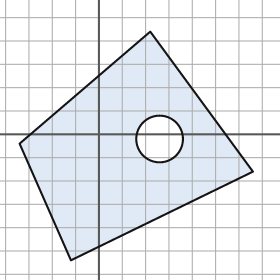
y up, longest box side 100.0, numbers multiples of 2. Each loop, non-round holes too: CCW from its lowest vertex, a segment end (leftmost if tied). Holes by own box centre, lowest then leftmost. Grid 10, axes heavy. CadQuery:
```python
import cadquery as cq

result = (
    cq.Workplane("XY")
    .moveTo(-12.0, -54.0)
    .lineTo(66.0, -16.0)
    .lineTo(22.0, 44.0)
    .lineTo(-34.0, -4.0)
    .close()
    .moveTo(26.0, -2.0)
    .circle(10.0)
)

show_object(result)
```